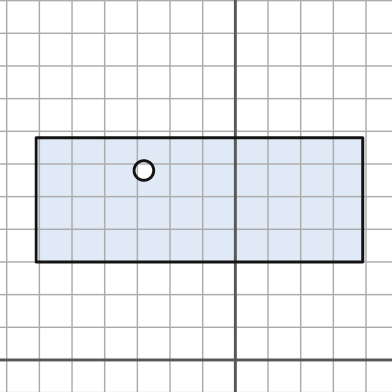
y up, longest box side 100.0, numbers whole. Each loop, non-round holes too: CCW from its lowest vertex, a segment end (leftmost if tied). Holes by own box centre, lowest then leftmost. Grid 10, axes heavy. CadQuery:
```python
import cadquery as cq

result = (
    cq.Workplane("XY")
    .moveTo(-61.0, 30.0)
    .lineTo(39.0, 30.0)
    .lineTo(39.0, 68.0)
    .lineTo(-61.0, 68.0)
    .close()
    .moveTo(-28.0, 58.0)
    .circle(3.0)
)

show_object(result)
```